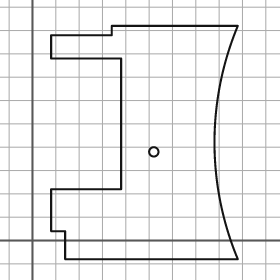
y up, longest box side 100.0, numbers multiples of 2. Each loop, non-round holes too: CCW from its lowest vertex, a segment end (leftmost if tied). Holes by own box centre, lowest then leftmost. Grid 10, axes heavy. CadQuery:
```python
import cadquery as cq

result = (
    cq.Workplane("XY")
    .moveTo(14.0, -8.0)
    .lineTo(88.0, -8.0)
    .threePointArc((78.0, 42.0), (88.0, 92.0))
    .lineTo(34.0, 92.0)
    .lineTo(34.0, 88.0)
    .lineTo(8.0, 88.0)
    .lineTo(8.0, 78.0)
    .lineTo(38.0, 78.0)
    .lineTo(38.0, 22.0)
    .lineTo(8.0, 22.0)
    .lineTo(8.0, 4.0)
    .lineTo(14.0, 4.0)
    .close()
    .moveTo(52.0, 38.0)
    .circle(2.0)
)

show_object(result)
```